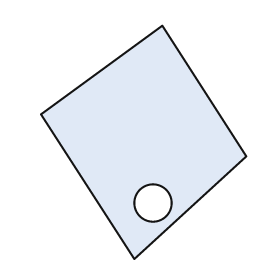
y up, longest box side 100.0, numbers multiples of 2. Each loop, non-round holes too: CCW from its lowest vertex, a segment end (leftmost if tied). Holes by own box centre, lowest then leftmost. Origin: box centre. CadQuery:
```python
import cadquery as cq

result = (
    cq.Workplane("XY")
    .moveTo(-4.0, -50.0)
    .lineTo(44.0, -6.0)
    .lineTo(8.0, 50.0)
    .lineTo(-44.0, 12.0)
    .close()
    .moveTo(4.0, -26.0)
    .circle(8.0)
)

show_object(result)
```